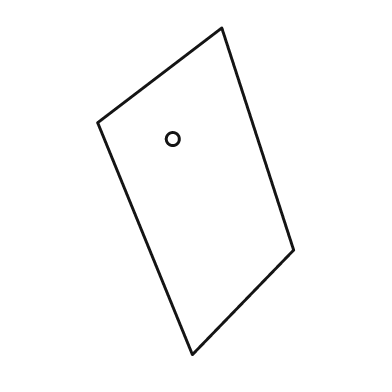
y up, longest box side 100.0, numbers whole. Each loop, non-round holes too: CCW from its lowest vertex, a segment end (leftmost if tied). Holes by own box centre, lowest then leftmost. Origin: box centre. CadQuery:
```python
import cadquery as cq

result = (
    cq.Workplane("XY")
    .moveTo(-1.0, -50.0)
    .lineTo(30.0, -18.0)
    .lineTo(8.0, 50.0)
    .lineTo(-30.0, 21.0)
    .close()
    .moveTo(-7.0, 16.0)
    .circle(2.0)
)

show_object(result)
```